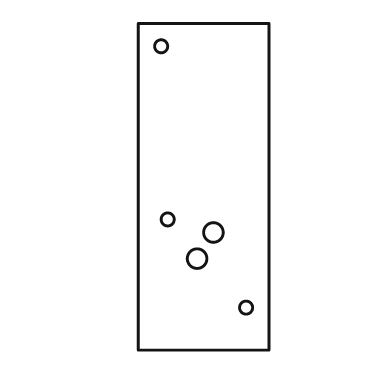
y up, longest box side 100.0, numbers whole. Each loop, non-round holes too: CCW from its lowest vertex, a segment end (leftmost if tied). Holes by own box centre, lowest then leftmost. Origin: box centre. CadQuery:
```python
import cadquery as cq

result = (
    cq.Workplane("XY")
    .moveTo(-20.0, -50.0)
    .lineTo(20.0, -50.0)
    .lineTo(20.0, 50.0)
    .lineTo(-20.0, 50.0)
    .close()
    .moveTo(13.0, -37.0)
    .circle(2.0)
    .moveTo(-2.0, -22.0)
    .circle(3.0)
    .moveTo(3.0, -14.0)
    .circle(3.0)
    .moveTo(-11.0, -10.0)
    .circle(2.0)
    .moveTo(-13.0, 43.0)
    .circle(2.0)
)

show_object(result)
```